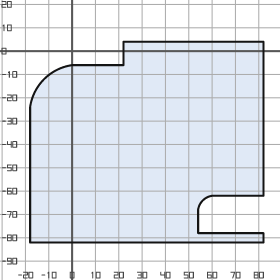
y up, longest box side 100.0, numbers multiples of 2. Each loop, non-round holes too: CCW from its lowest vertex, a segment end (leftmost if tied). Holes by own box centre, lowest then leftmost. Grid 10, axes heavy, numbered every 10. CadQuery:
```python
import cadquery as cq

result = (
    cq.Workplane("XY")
    .moveTo(-18.0, -82.0)
    .lineTo(82.0, -82.0)
    .lineTo(82.0, -78.0)
    .lineTo(54.0, -78.0)
    .lineTo(54.0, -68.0)
    .threePointArc((56.0, -64.0), (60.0, -62.0))
    .lineTo(82.0, -62.0)
    .lineTo(82.0, 4.0)
    .lineTo(22.0, 4.0)
    .lineTo(22.0, -6.0)
    .lineTo(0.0, -6.0)
    .threePointArc((-12.0, -12.0), (-18.0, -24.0))
    .close()
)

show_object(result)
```